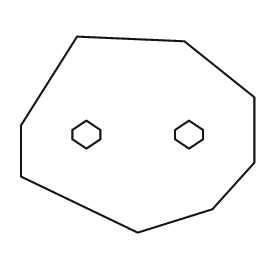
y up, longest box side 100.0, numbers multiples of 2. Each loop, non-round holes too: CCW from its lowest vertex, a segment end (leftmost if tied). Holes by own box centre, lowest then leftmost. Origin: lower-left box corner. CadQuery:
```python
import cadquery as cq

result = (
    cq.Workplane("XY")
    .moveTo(50.0, 0.0)
    .lineTo(82.0, 10.0)
    .lineTo(100.0, 30.0)
    .lineTo(100.0, 58.0)
    .lineTo(70.0, 82.0)
    .lineTo(24.0, 84.0)
    .lineTo(0.0, 46.0)
    .lineTo(0.0, 24.0)
    .close()
    .moveTo(28.0, 36.0)
    .lineTo(34.0, 40.0)
    .lineTo(34.0, 44.0)
    .lineTo(28.0, 48.0)
    .lineTo(22.0, 44.0)
    .lineTo(22.0, 40.0)
    .close()
    .moveTo(72.0, 36.0)
    .lineTo(78.0, 40.0)
    .lineTo(78.0, 44.0)
    .lineTo(72.0, 48.0)
    .lineTo(66.0, 44.0)
    .lineTo(66.0, 40.0)
    .close()
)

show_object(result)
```